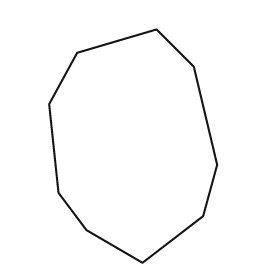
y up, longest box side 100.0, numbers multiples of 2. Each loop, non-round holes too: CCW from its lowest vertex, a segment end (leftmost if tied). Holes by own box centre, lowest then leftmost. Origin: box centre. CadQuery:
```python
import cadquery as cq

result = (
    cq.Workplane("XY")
    .moveTo(4.0, -50.0)
    .lineTo(30.0, -30.0)
    .lineTo(36.0, -8.0)
    .lineTo(26.0, 34.0)
    .lineTo(10.0, 50.0)
    .lineTo(-24.0, 40.0)
    .lineTo(-36.0, 18.0)
    .lineTo(-32.0, -20.0)
    .lineTo(-20.0, -36.0)
    .close()
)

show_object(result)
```